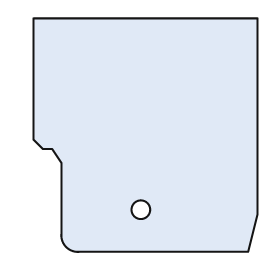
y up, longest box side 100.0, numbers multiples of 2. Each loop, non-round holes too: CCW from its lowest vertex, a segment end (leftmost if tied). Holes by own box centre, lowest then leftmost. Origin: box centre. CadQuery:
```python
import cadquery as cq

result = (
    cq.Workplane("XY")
    .moveTo(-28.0, -50.0)
    .lineTo(44.0, -50.0)
    .lineTo(48.0, -34.0)
    .lineTo(48.0, 50.0)
    .lineTo(-48.0, 50.0)
    .lineTo(-48.0, -2.0)
    .lineTo(-44.0, -6.0)
    .lineTo(-40.0, -6.0)
    .lineTo(-36.0, -12.0)
    .lineTo(-36.0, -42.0)
    .threePointArc((-34.0, -48.0), (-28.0, -50.0))
    .close()
    .moveTo(-2.0, -32.0)
    .circle(4.0)
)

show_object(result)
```